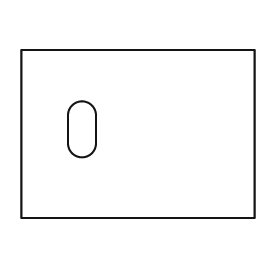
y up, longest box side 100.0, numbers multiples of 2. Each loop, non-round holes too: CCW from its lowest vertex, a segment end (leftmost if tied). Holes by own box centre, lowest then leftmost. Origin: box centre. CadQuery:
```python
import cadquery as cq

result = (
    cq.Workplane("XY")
    .moveTo(-50.0, -36.0)
    .lineTo(50.0, -36.0)
    .lineTo(50.0, 36.0)
    .lineTo(-50.0, 36.0)
    .close()
    .moveTo(-30.0, -4.0)
    .threePointArc((-24.0, -10.0), (-18.0, -4.0))
    .lineTo(-18.0, 8.0)
    .threePointArc((-24.0, 14.0), (-30.0, 8.0))
    .close()
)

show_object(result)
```